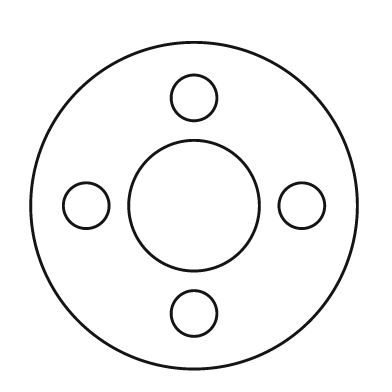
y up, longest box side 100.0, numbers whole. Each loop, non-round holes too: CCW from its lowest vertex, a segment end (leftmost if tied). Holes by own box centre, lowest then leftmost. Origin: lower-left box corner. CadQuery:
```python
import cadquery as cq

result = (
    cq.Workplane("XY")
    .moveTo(50.0, 50.0)
    .circle(50.0)
    .moveTo(50.0, 17.0)
    .circle(7.0)
    .moveTo(17.0, 50.0)
    .circle(7.0)
    .moveTo(50.0, 50.0)
    .circle(20.0)
    .moveTo(83.0, 50.0)
    .circle(7.0)
    .moveTo(50.0, 83.0)
    .circle(7.0)
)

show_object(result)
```